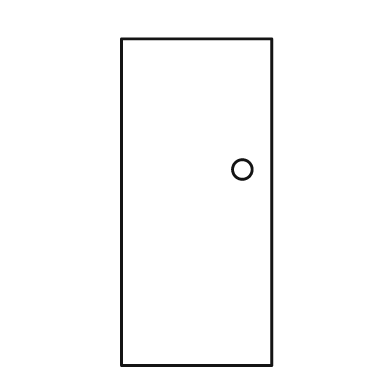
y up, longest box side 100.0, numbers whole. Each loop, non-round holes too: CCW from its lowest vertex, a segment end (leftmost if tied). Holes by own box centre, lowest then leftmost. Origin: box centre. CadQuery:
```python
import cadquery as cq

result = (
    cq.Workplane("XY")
    .moveTo(-23.0, -50.0)
    .lineTo(23.0, -50.0)
    .lineTo(23.0, 50.0)
    .lineTo(-23.0, 50.0)
    .close()
    .moveTo(14.0, 10.0)
    .circle(3.0)
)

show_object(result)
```